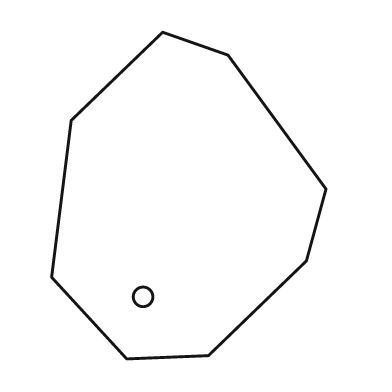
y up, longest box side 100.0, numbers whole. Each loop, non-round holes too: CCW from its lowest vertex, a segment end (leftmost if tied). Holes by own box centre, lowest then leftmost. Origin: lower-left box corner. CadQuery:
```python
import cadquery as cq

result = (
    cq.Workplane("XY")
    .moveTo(23.0, 0.0)
    .lineTo(48.0, 1.0)
    .lineTo(78.0, 30.0)
    .lineTo(84.0, 52.0)
    .lineTo(54.0, 93.0)
    .lineTo(34.0, 100.0)
    .lineTo(6.0, 73.0)
    .lineTo(0.0, 25.0)
    .close()
    .moveTo(28.0, 19.0)
    .circle(3.0)
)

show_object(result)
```